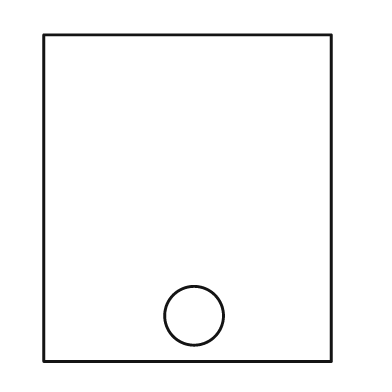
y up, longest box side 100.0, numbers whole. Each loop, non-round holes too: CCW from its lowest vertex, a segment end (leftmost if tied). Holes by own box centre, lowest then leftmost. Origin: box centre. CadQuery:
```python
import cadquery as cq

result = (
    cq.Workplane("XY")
    .moveTo(-44.0, -50.0)
    .lineTo(44.0, -50.0)
    .lineTo(44.0, 50.0)
    .lineTo(-44.0, 50.0)
    .close()
    .moveTo(2.0, -36.0)
    .circle(9.0)
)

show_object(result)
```